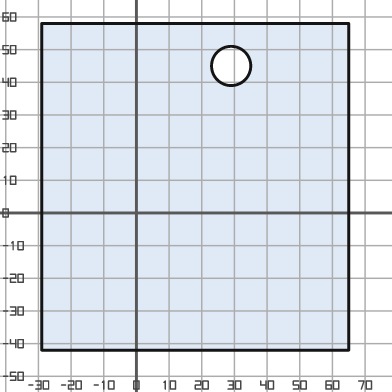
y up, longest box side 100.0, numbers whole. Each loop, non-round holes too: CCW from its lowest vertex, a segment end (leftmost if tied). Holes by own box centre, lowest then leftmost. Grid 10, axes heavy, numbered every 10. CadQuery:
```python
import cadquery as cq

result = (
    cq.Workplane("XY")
    .moveTo(-29.0, -42.0)
    .lineTo(65.0, -42.0)
    .lineTo(65.0, 58.0)
    .lineTo(-29.0, 58.0)
    .close()
    .moveTo(29.0, 45.0)
    .circle(6.0)
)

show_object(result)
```